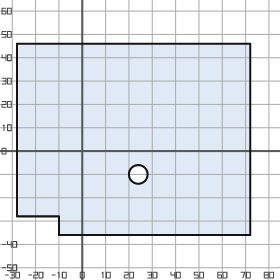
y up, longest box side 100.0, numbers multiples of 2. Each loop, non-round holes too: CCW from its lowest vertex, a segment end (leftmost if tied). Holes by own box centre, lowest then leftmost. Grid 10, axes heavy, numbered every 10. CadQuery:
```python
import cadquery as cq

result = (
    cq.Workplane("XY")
    .moveTo(-10.0, -36.0)
    .lineTo(72.0, -36.0)
    .lineTo(72.0, 46.0)
    .lineTo(-28.0, 46.0)
    .lineTo(-28.0, -28.0)
    .lineTo(-10.0, -28.0)
    .close()
    .moveTo(24.0, -10.0)
    .circle(4.0)
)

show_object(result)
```